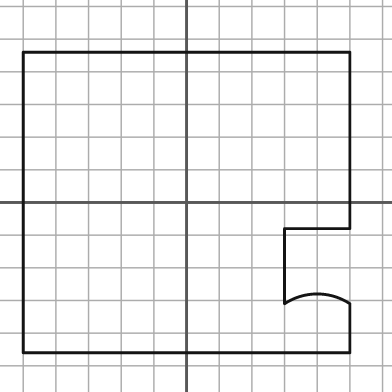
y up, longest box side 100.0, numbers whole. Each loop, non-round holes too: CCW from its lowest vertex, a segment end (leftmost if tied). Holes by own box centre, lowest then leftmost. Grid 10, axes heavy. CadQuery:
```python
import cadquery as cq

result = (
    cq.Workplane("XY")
    .moveTo(-50.0, -46.0)
    .lineTo(50.0, -46.0)
    .lineTo(50.0, -31.0)
    .threePointArc((40.0, -28.0), (30.0, -31.0))
    .lineTo(30.0, -8.0)
    .lineTo(50.0, -8.0)
    .lineTo(50.0, 46.0)
    .lineTo(-50.0, 46.0)
    .close()
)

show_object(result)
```